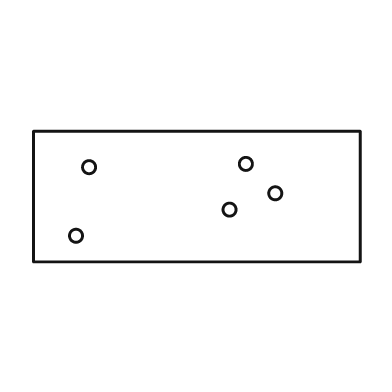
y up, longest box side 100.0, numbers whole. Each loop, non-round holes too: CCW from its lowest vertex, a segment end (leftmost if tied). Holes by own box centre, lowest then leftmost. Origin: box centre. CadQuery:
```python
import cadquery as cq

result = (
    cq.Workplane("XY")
    .moveTo(-50.0, -20.0)
    .lineTo(50.0, -20.0)
    .lineTo(50.0, 20.0)
    .lineTo(-50.0, 20.0)
    .close()
    .moveTo(-37.0, -12.0)
    .circle(2.0)
    .moveTo(10.0, -4.0)
    .circle(2.0)
    .moveTo(24.0, 1.0)
    .circle(2.0)
    .moveTo(-33.0, 9.0)
    .circle(2.0)
    .moveTo(15.0, 10.0)
    .circle(2.0)
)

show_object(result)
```